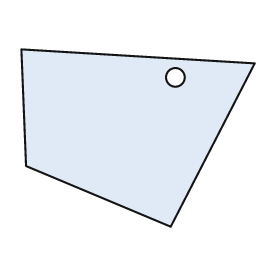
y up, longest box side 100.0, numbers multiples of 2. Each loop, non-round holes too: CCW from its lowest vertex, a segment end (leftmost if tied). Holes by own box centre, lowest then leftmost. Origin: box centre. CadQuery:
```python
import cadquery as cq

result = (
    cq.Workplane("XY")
    .moveTo(14.0, -38.0)
    .lineTo(50.0, 32.0)
    .lineTo(-50.0, 38.0)
    .lineTo(-48.0, -12.0)
    .close()
    .moveTo(16.0, 26.0)
    .circle(4.0)
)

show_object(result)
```